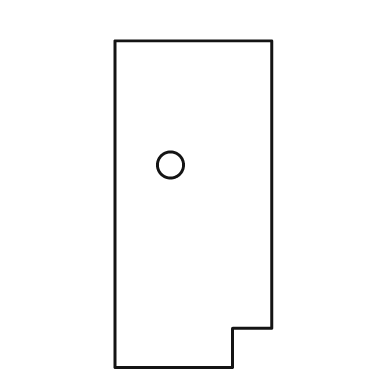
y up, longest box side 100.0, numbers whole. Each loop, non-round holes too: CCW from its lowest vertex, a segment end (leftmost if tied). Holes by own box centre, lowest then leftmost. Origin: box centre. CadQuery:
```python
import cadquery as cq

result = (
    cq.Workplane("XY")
    .moveTo(-24.0, -50.0)
    .lineTo(12.0, -50.0)
    .lineTo(12.0, -38.0)
    .lineTo(24.0, -38.0)
    .lineTo(24.0, 50.0)
    .lineTo(-24.0, 50.0)
    .close()
    .moveTo(-7.0, 12.0)
    .circle(4.0)
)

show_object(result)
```